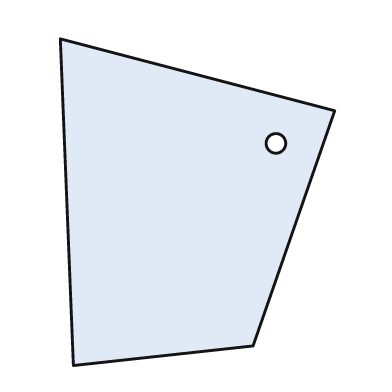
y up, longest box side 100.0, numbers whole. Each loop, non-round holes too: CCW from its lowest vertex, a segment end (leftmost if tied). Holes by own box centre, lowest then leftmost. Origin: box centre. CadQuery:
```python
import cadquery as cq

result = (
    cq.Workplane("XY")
    .moveTo(-38.0, -50.0)
    .lineTo(17.0, -44.0)
    .lineTo(42.0, 28.0)
    .lineTo(-42.0, 50.0)
    .close()
    .moveTo(24.0, 18.0)
    .circle(3.0)
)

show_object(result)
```